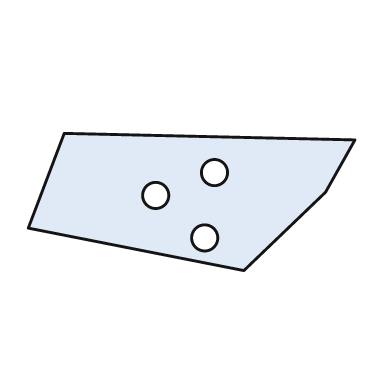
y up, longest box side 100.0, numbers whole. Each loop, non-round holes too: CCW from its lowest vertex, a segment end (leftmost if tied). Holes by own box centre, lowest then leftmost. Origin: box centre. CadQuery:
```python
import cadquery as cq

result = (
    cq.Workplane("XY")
    .moveTo(16.0, -21.0)
    .lineTo(41.0, 3.0)
    .lineTo(50.0, 19.0)
    .lineTo(-39.0, 21.0)
    .lineTo(-50.0, -8.0)
    .close()
    .moveTo(4.0, -11.0)
    .circle(4.0)
    .moveTo(-11.0, 2.0)
    .circle(4.0)
    .moveTo(7.0, 9.0)
    .circle(4.0)
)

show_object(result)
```